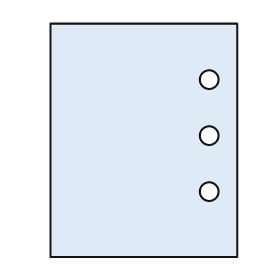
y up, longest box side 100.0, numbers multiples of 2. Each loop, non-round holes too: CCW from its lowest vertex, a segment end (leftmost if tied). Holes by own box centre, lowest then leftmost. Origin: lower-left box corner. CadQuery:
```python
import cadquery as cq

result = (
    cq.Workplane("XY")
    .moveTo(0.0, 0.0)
    .lineTo(80.0, 0.0)
    .lineTo(80.0, 100.0)
    .lineTo(0.0, 100.0)
    .close()
    .moveTo(68.0, 28.0)
    .circle(4.0)
    .moveTo(68.0, 52.0)
    .circle(4.0)
    .moveTo(68.0, 76.0)
    .circle(4.0)
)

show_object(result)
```